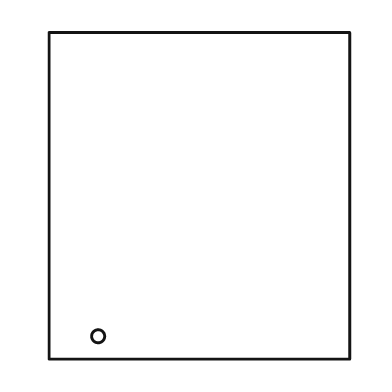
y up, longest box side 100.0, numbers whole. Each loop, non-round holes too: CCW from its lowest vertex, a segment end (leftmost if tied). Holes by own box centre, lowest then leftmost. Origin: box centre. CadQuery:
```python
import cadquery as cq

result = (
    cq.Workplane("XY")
    .moveTo(-46.0, -50.0)
    .lineTo(46.0, -50.0)
    .lineTo(46.0, 50.0)
    .lineTo(-46.0, 50.0)
    .close()
    .moveTo(-31.0, -43.0)
    .circle(2.0)
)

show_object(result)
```